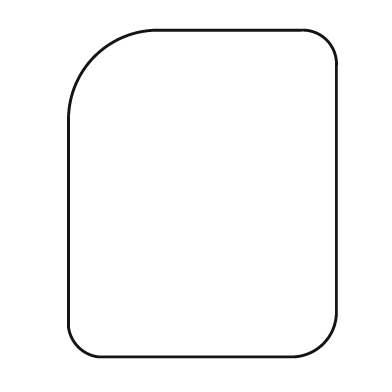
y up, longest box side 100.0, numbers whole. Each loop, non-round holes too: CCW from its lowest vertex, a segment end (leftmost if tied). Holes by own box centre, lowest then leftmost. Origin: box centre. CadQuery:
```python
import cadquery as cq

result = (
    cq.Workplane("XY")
    .moveTo(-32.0, -50.0)
    .lineTo(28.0, -50.0)
    .threePointArc((37.0, -46.0), (41.0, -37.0))
    .lineTo(41.0, 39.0)
    .threePointArc((38.0, 47.0), (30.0, 50.0))
    .lineTo(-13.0, 50.0)
    .threePointArc((-33.0, 42.0), (-41.0, 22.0))
    .lineTo(-41.0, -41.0)
    .threePointArc((-38.0, -47.0), (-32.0, -50.0))
    .close()
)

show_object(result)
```